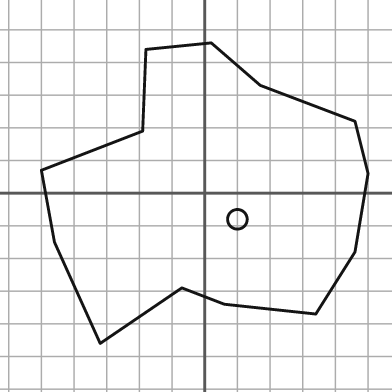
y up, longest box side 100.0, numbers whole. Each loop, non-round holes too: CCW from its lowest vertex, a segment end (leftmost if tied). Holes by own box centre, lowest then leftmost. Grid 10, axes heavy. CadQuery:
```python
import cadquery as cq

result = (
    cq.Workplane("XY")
    .moveTo(-32.0, -46.0)
    .lineTo(-7.0, -29.0)
    .lineTo(6.0, -34.0)
    .lineTo(34.0, -37.0)
    .lineTo(46.0, -18.0)
    .lineTo(50.0, 6.0)
    .lineTo(46.0, 22.0)
    .lineTo(17.0, 33.0)
    .lineTo(2.0, 46.0)
    .lineTo(-18.0, 44.0)
    .lineTo(-19.0, 19.0)
    .lineTo(-50.0, 7.0)
    .lineTo(-46.0, -15.0)
    .close()
    .moveTo(10.0, -8.0)
    .circle(3.0)
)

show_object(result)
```